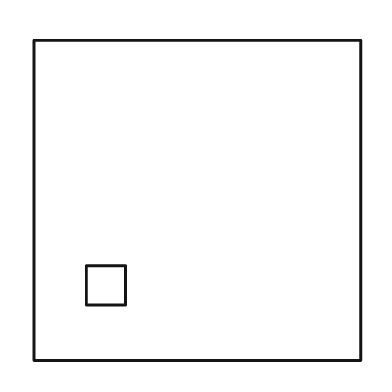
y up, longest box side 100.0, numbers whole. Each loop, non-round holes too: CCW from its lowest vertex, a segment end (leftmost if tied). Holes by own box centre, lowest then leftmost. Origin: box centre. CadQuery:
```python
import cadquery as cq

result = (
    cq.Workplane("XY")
    .moveTo(-50.0, -49.0)
    .lineTo(50.0, -49.0)
    .lineTo(50.0, 49.0)
    .lineTo(-50.0, 49.0)
    .close()
    .moveTo(-34.0, -32.0)
    .lineTo(-22.0, -32.0)
    .lineTo(-22.0, -20.0)
    .lineTo(-34.0, -20.0)
    .close()
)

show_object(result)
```